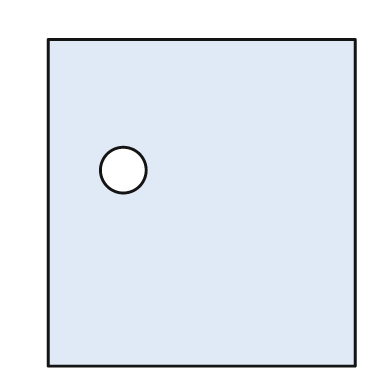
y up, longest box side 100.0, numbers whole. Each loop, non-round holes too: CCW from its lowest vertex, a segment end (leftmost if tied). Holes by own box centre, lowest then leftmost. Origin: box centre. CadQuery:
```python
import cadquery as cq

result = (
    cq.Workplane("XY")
    .moveTo(-47.0, -50.0)
    .lineTo(47.0, -50.0)
    .lineTo(47.0, 50.0)
    .lineTo(-47.0, 50.0)
    .close()
    .moveTo(-24.0, 10.0)
    .circle(7.0)
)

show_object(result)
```